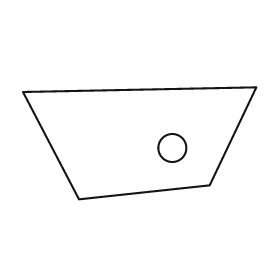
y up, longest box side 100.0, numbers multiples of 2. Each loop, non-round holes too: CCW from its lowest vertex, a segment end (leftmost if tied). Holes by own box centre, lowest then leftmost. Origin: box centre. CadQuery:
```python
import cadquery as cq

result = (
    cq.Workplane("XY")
    .moveTo(-26.0, -24.0)
    .lineTo(30.0, -18.0)
    .lineTo(50.0, 24.0)
    .lineTo(-50.0, 22.0)
    .close()
    .moveTo(14.0, -2.0)
    .circle(6.0)
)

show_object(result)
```